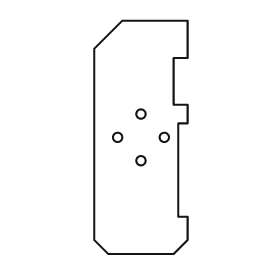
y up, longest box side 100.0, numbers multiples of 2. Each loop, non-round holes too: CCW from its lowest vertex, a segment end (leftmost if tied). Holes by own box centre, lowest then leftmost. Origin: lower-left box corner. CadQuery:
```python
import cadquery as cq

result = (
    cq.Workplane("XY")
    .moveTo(6.0, 0.0)
    .lineTo(34.0, 0.0)
    .lineTo(40.0, 6.0)
    .lineTo(40.0, 16.0)
    .lineTo(36.0, 16.0)
    .lineTo(36.0, 56.0)
    .lineTo(40.0, 56.0)
    .lineTo(40.0, 64.0)
    .lineTo(34.0, 64.0)
    .lineTo(34.0, 84.0)
    .lineTo(40.0, 84.0)
    .lineTo(40.0, 100.0)
    .lineTo(12.0, 100.0)
    .lineTo(0.0, 88.0)
    .lineTo(0.0, 6.0)
    .close()
    .moveTo(20.0, 40.0)
    .circle(2.0)
    .moveTo(10.0, 50.0)
    .circle(2.0)
    .moveTo(30.0, 50.0)
    .circle(2.0)
    .moveTo(20.0, 60.0)
    .circle(2.0)
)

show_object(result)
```